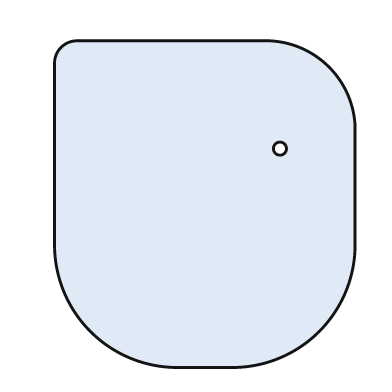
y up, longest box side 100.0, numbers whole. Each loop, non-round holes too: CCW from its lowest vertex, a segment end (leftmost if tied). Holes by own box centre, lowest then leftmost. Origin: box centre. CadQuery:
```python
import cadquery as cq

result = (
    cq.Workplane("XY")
    .moveTo(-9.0, -50.0)
    .lineTo(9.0, -50.0)
    .threePointArc((35.0, -39.0), (46.0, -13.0))
    .lineTo(46.0, 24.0)
    .threePointArc((38.0, 42.0), (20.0, 50.0))
    .lineTo(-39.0, 50.0)
    .threePointArc((-44.0, 48.0), (-46.0, 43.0))
    .lineTo(-46.0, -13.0)
    .threePointArc((-35.0, -39.0), (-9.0, -50.0))
    .close()
    .moveTo(23.0, 17.0)
    .circle(2.0)
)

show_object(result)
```